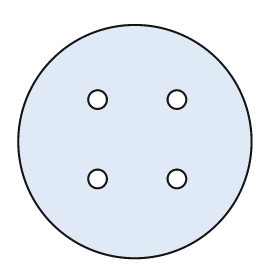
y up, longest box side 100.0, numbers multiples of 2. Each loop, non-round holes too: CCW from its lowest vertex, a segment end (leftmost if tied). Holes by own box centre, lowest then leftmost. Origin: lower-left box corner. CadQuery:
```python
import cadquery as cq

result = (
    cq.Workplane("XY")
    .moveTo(50.0, 50.0)
    .circle(50.0)
    .moveTo(34.0, 34.0)
    .circle(4.0)
    .moveTo(68.0, 34.0)
    .circle(4.0)
    .moveTo(34.0, 68.0)
    .circle(4.0)
    .moveTo(68.0, 68.0)
    .circle(4.0)
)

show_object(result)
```